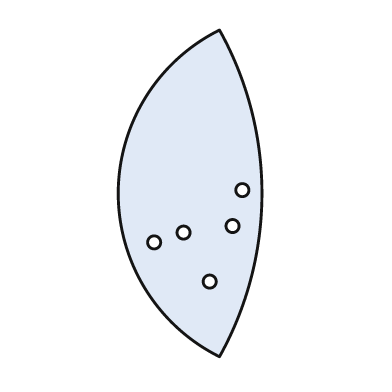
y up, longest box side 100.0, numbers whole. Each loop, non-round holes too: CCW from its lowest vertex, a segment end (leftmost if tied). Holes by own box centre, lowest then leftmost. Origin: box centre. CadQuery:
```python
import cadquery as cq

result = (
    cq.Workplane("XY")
    .moveTo(9.0, -50.0)
    .threePointArc((22.0, 0.0), (9.0, 50.0))
    .threePointArc((-22.0, 0.0), (9.0, -50.0))
    .close()
    .moveTo(6.0, -27.0)
    .circle(2.0)
    .moveTo(-11.0, -15.0)
    .circle(2.0)
    .moveTo(-2.0, -12.0)
    .circle(2.0)
    .moveTo(13.0, -10.0)
    .circle(2.0)
    .moveTo(16.0, 1.0)
    .circle(2.0)
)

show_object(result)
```